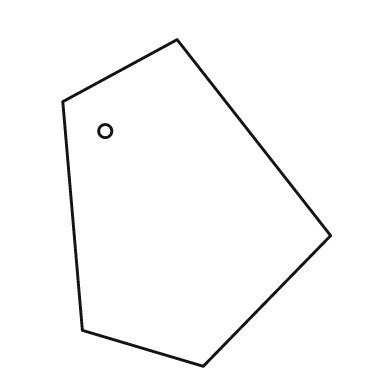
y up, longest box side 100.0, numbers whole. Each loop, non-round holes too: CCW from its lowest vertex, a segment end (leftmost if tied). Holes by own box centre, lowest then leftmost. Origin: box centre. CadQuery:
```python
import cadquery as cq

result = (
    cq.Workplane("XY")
    .moveTo(2.0, -50.0)
    .lineTo(41.0, -10.0)
    .lineTo(-6.0, 50.0)
    .lineTo(-41.0, 31.0)
    .lineTo(-35.0, -39.0)
    .close()
    .moveTo(-28.0, 22.0)
    .circle(2.0)
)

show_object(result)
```